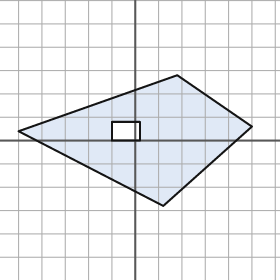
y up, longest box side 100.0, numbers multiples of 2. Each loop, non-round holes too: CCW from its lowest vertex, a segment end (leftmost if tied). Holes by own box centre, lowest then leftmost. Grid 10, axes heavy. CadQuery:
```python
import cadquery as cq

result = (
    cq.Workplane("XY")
    .moveTo(12.0, -28.0)
    .lineTo(50.0, 6.0)
    .lineTo(18.0, 28.0)
    .lineTo(-50.0, 4.0)
    .close()
    .moveTo(-10.0, 0.0)
    .lineTo(2.0, 0.0)
    .lineTo(2.0, 8.0)
    .lineTo(-10.0, 8.0)
    .close()
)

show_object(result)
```